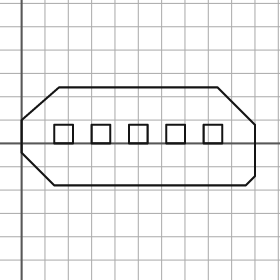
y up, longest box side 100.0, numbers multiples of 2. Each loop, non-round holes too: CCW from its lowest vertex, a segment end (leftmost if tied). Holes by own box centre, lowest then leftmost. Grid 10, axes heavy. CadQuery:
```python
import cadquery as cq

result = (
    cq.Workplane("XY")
    .moveTo(14.0, -18.0)
    .lineTo(96.0, -18.0)
    .lineTo(100.0, -14.0)
    .lineTo(100.0, 8.0)
    .lineTo(84.0, 24.0)
    .lineTo(16.0, 24.0)
    .lineTo(0.0, 10.0)
    .lineTo(0.0, -4.0)
    .close()
    .moveTo(14.0, 0.0)
    .lineTo(22.0, 0.0)
    .lineTo(22.0, 8.0)
    .lineTo(14.0, 8.0)
    .close()
    .moveTo(30.0, 0.0)
    .lineTo(38.0, 0.0)
    .lineTo(38.0, 8.0)
    .lineTo(30.0, 8.0)
    .close()
    .moveTo(46.0, 0.0)
    .lineTo(54.0, 0.0)
    .lineTo(54.0, 8.0)
    .lineTo(46.0, 8.0)
    .close()
    .moveTo(62.0, 0.0)
    .lineTo(70.0, 0.0)
    .lineTo(70.0, 8.0)
    .lineTo(62.0, 8.0)
    .close()
    .moveTo(78.0, 0.0)
    .lineTo(86.0, 0.0)
    .lineTo(86.0, 8.0)
    .lineTo(78.0, 8.0)
    .close()
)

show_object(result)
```